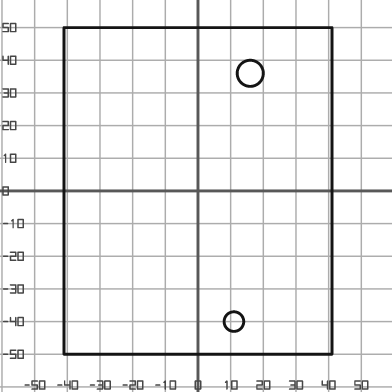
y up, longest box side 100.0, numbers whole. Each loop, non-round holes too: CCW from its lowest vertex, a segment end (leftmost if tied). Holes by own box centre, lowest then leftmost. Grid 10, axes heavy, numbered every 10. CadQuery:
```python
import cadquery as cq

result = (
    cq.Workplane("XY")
    .moveTo(-41.0, -50.0)
    .lineTo(41.0, -50.0)
    .lineTo(41.0, 50.0)
    .lineTo(-41.0, 50.0)
    .close()
    .moveTo(11.0, -40.0)
    .circle(3.0)
    .moveTo(16.0, 36.0)
    .circle(4.0)
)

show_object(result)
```